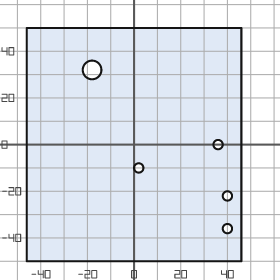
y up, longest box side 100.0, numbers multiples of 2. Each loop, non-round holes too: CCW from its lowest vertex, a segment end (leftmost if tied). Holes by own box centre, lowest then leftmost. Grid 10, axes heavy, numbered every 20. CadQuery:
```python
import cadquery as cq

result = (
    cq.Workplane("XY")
    .moveTo(-46.0, -50.0)
    .lineTo(46.0, -50.0)
    .lineTo(46.0, 50.0)
    .lineTo(-46.0, 50.0)
    .close()
    .moveTo(40.0, -36.0)
    .circle(2.0)
    .moveTo(40.0, -22.0)
    .circle(2.0)
    .moveTo(2.0, -10.0)
    .circle(2.0)
    .moveTo(36.0, 0.0)
    .circle(2.0)
    .moveTo(-18.0, 32.0)
    .circle(4.0)
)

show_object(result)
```